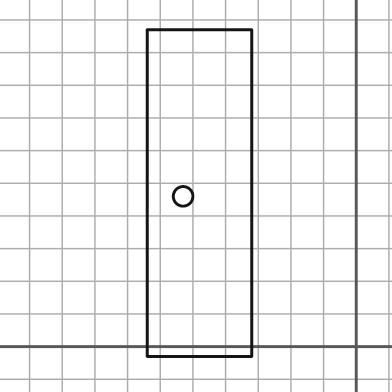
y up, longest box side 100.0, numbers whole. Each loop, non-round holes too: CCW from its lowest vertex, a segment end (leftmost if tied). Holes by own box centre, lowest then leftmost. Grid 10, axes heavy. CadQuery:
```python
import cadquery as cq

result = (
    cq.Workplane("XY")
    .moveTo(-64.0, -3.0)
    .lineTo(-32.0, -3.0)
    .lineTo(-32.0, 97.0)
    .lineTo(-64.0, 97.0)
    .close()
    .moveTo(-53.0, 46.0)
    .circle(3.0)
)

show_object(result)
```